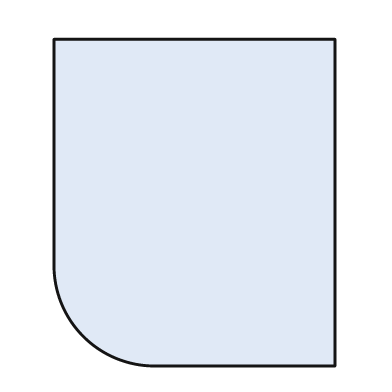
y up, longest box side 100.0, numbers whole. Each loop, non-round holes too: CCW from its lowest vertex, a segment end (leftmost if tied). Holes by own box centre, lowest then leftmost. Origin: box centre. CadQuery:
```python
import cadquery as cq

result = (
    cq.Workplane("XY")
    .moveTo(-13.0, -50.0)
    .lineTo(43.0, -50.0)
    .lineTo(43.0, 50.0)
    .lineTo(-43.0, 50.0)
    .lineTo(-43.0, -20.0)
    .threePointArc((-34.0, -41.0), (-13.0, -50.0))
    .close()
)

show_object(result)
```